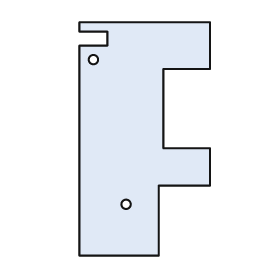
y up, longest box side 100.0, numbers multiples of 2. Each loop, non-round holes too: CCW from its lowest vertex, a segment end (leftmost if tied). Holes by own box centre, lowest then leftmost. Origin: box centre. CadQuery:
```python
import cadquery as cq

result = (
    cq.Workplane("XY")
    .moveTo(-28.0, -50.0)
    .lineTo(6.0, -50.0)
    .lineTo(6.0, -20.0)
    .lineTo(28.0, -20.0)
    .lineTo(28.0, -4.0)
    .lineTo(8.0, -4.0)
    .lineTo(8.0, 30.0)
    .lineTo(28.0, 30.0)
    .lineTo(28.0, 50.0)
    .lineTo(-28.0, 50.0)
    .lineTo(-28.0, 46.0)
    .lineTo(-16.0, 46.0)
    .lineTo(-16.0, 40.0)
    .lineTo(-28.0, 40.0)
    .close()
    .moveTo(-8.0, -28.0)
    .circle(2.0)
    .moveTo(-22.0, 34.0)
    .circle(2.0)
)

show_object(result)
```